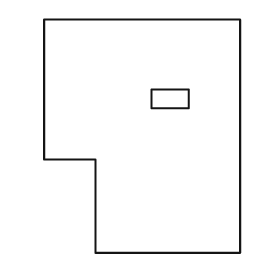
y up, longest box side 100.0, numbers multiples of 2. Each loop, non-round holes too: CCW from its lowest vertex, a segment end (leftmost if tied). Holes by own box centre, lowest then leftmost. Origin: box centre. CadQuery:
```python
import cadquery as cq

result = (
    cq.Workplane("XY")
    .moveTo(-20.0, -50.0)
    .lineTo(42.0, -50.0)
    .lineTo(42.0, 50.0)
    .lineTo(-42.0, 50.0)
    .lineTo(-42.0, -10.0)
    .lineTo(-20.0, -10.0)
    .close()
    .moveTo(4.0, 12.0)
    .lineTo(20.0, 12.0)
    .lineTo(20.0, 20.0)
    .lineTo(4.0, 20.0)
    .close()
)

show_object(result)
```